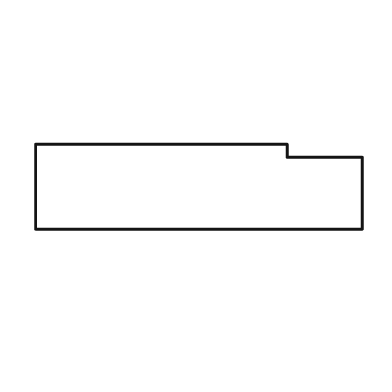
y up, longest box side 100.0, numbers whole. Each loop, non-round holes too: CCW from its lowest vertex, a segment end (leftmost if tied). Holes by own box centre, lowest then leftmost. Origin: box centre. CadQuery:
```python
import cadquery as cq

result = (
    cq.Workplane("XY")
    .moveTo(-50.0, -13.0)
    .lineTo(50.0, -13.0)
    .lineTo(50.0, 9.0)
    .lineTo(27.0, 9.0)
    .lineTo(27.0, 13.0)
    .lineTo(-50.0, 13.0)
    .close()
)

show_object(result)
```